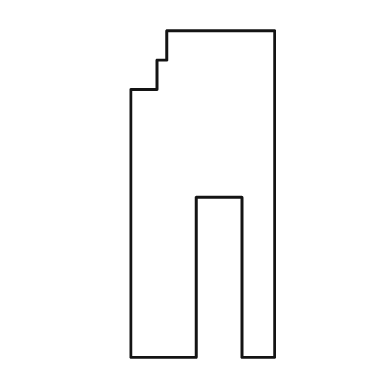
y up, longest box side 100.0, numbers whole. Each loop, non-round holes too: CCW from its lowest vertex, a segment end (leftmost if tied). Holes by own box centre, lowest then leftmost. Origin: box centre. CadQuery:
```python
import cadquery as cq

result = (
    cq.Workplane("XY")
    .moveTo(-22.0, -50.0)
    .lineTo(-2.0, -50.0)
    .lineTo(-2.0, -1.0)
    .lineTo(12.0, -1.0)
    .lineTo(12.0, -50.0)
    .lineTo(22.0, -50.0)
    .lineTo(22.0, 50.0)
    .lineTo(-11.0, 50.0)
    .lineTo(-11.0, 41.0)
    .lineTo(-14.0, 41.0)
    .lineTo(-14.0, 32.0)
    .lineTo(-22.0, 32.0)
    .close()
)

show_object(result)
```